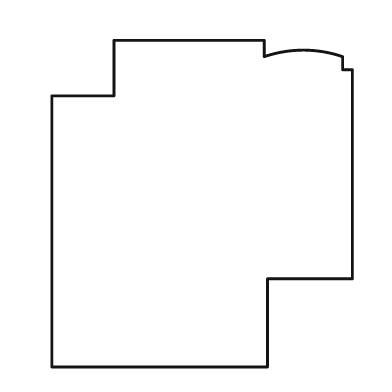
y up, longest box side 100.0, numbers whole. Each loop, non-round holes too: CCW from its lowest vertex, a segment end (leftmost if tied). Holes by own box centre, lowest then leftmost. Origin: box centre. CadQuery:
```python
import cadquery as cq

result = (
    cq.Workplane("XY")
    .moveTo(-46.0, -50.0)
    .lineTo(20.0, -50.0)
    .lineTo(20.0, -23.0)
    .lineTo(46.0, -23.0)
    .lineTo(46.0, 41.0)
    .lineTo(43.0, 41.0)
    .lineTo(43.0, 45.0)
    .threePointArc((31.0, 47.0), (19.0, 45.0))
    .lineTo(19.0, 50.0)
    .lineTo(-27.0, 50.0)
    .lineTo(-27.0, 33.0)
    .lineTo(-46.0, 33.0)
    .close()
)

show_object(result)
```